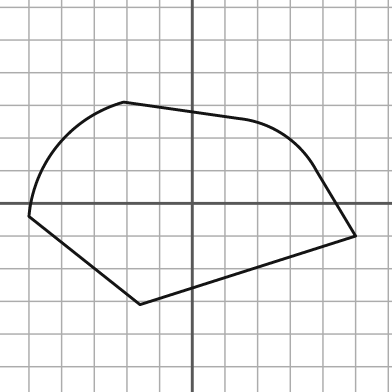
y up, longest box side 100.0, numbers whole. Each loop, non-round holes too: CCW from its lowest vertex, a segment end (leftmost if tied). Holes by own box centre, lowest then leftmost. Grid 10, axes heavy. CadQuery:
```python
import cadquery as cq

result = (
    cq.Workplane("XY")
    .moveTo(-16.0, -31.0)
    .lineTo(50.0, -10.0)
    .lineTo(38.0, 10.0)
    .threePointArc((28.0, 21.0), (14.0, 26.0))
    .lineTo(-21.0, 31.0)
    .threePointArc((-41.0, 18.0), (-50.0, -4.0))
    .close()
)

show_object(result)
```